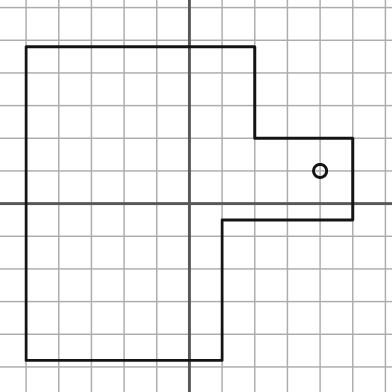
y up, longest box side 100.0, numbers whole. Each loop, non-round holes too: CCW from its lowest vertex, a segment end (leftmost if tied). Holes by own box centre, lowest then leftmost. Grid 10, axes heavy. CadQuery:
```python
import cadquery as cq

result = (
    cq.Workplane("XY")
    .moveTo(-50.0, -48.0)
    .lineTo(10.0, -48.0)
    .lineTo(10.0, -5.0)
    .lineTo(50.0, -5.0)
    .lineTo(50.0, 20.0)
    .lineTo(20.0, 20.0)
    .lineTo(20.0, 48.0)
    .lineTo(-50.0, 48.0)
    .close()
    .moveTo(40.0, 10.0)
    .circle(2.0)
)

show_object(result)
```